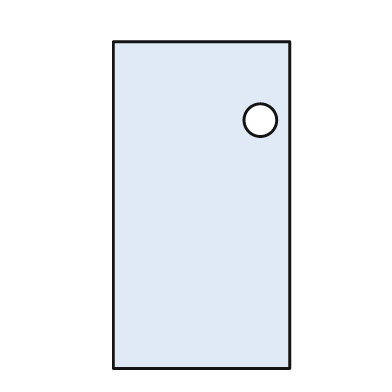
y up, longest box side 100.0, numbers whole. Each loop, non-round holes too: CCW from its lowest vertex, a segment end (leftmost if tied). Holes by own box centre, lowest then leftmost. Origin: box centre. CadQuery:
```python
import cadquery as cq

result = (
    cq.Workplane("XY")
    .moveTo(-27.0, -50.0)
    .lineTo(27.0, -50.0)
    .lineTo(27.0, 50.0)
    .lineTo(-27.0, 50.0)
    .close()
    .moveTo(18.0, 26.0)
    .circle(5.0)
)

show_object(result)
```